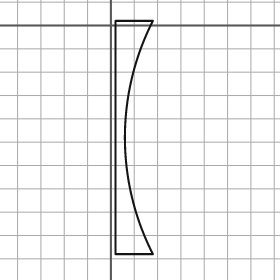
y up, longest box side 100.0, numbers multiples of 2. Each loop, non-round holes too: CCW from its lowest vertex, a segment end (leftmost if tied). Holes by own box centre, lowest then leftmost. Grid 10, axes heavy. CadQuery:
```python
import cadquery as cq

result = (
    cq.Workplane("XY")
    .moveTo(2.0, -98.0)
    .lineTo(18.0, -98.0)
    .threePointArc((6.0, -48.0), (18.0, 2.0))
    .lineTo(2.0, 2.0)
    .close()
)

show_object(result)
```